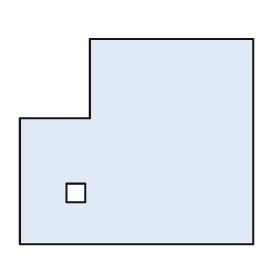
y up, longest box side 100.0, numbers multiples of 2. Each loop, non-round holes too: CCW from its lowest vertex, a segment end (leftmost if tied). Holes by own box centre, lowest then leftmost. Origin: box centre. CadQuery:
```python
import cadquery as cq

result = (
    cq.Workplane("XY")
    .moveTo(-50.0, -44.0)
    .lineTo(50.0, -44.0)
    .lineTo(50.0, 44.0)
    .lineTo(-20.0, 44.0)
    .lineTo(-20.0, 10.0)
    .lineTo(-50.0, 10.0)
    .close()
    .moveTo(-30.0, -26.0)
    .lineTo(-22.0, -26.0)
    .lineTo(-22.0, -18.0)
    .lineTo(-30.0, -18.0)
    .close()
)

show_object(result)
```